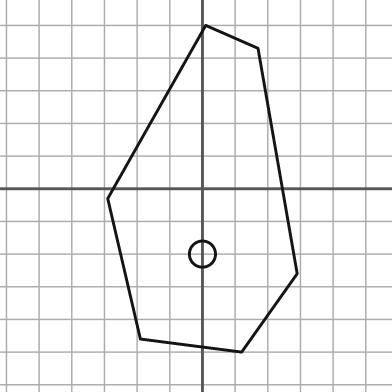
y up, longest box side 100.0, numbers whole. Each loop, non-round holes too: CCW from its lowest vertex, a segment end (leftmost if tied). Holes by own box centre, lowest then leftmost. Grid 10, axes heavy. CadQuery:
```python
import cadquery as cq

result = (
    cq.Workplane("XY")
    .moveTo(12.0, -50.0)
    .lineTo(29.0, -26.0)
    .lineTo(17.0, 43.0)
    .lineTo(1.0, 50.0)
    .lineTo(-29.0, -3.0)
    .lineTo(-19.0, -46.0)
    .close()
    .moveTo(0.0, -20.0)
    .circle(4.0)
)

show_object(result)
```